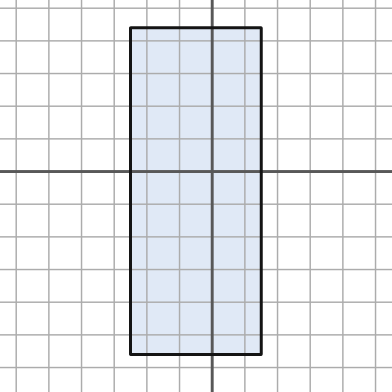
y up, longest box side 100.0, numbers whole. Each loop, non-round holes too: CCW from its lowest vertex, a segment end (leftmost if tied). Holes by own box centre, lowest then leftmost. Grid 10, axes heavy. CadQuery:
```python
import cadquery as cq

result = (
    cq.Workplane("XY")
    .moveTo(-25.0, -56.0)
    .lineTo(15.0, -56.0)
    .lineTo(15.0, 44.0)
    .lineTo(-25.0, 44.0)
    .close()
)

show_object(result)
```